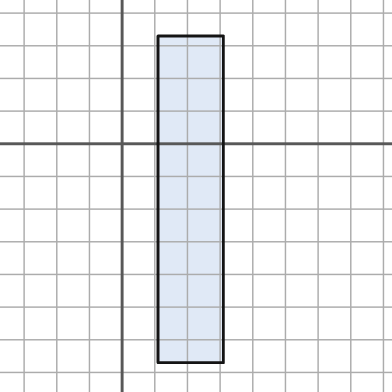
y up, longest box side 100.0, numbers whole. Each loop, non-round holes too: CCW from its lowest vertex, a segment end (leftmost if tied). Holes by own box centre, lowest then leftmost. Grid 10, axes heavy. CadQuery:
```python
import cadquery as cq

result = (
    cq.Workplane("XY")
    .moveTo(11.0, -67.0)
    .lineTo(31.0, -67.0)
    .lineTo(31.0, 33.0)
    .lineTo(11.0, 33.0)
    .close()
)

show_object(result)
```